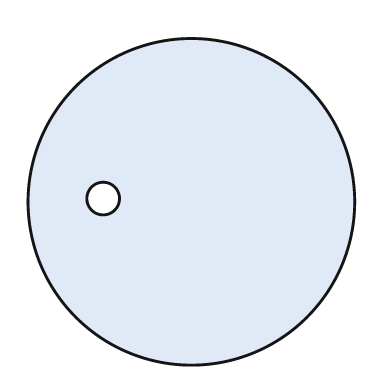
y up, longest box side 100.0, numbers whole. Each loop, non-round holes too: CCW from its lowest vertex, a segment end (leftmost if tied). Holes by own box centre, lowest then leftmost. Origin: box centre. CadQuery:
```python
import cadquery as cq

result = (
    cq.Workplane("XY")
    .moveTo(0.0, 0.0)
    .circle(50.0)
    .moveTo(-27.0, 1.0)
    .circle(5.0)
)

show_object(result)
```